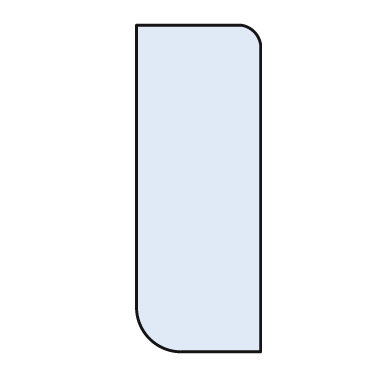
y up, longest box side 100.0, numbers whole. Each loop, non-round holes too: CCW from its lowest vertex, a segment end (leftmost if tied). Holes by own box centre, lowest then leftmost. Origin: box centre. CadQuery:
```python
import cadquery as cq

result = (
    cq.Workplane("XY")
    .moveTo(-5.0, -50.0)
    .lineTo(19.0, -50.0)
    .lineTo(19.0, 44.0)
    .threePointArc((17.0, 48.0), (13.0, 50.0))
    .lineTo(-19.0, 50.0)
    .lineTo(-19.0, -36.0)
    .threePointArc((-15.0, -46.0), (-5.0, -50.0))
    .close()
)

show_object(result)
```